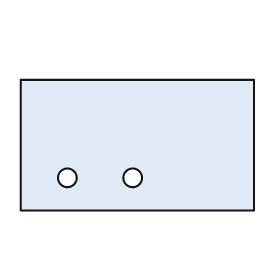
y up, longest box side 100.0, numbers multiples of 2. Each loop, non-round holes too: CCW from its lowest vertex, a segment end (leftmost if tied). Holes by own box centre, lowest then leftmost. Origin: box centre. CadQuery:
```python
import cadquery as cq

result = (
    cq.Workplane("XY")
    .moveTo(-50.0, -28.0)
    .lineTo(50.0, -28.0)
    .lineTo(50.0, 28.0)
    .lineTo(-50.0, 28.0)
    .close()
    .moveTo(-30.0, -14.0)
    .circle(4.0)
    .moveTo(-2.0, -14.0)
    .circle(4.0)
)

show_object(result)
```